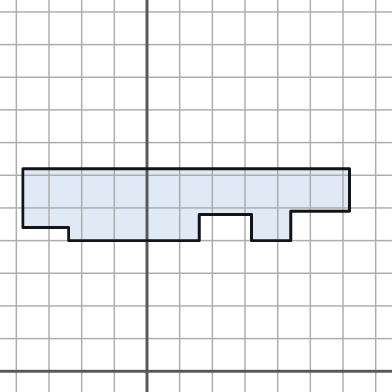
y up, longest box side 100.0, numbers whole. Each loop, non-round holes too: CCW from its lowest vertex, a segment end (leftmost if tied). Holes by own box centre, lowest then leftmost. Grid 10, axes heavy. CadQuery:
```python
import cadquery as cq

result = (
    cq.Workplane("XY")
    .moveTo(-24.0, 40.0)
    .lineTo(16.0, 40.0)
    .lineTo(16.0, 48.0)
    .lineTo(32.0, 48.0)
    .lineTo(32.0, 40.0)
    .lineTo(44.0, 40.0)
    .lineTo(44.0, 49.0)
    .lineTo(62.0, 49.0)
    .lineTo(62.0, 62.0)
    .lineTo(-38.0, 62.0)
    .lineTo(-38.0, 44.0)
    .lineTo(-24.0, 44.0)
    .close()
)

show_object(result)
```